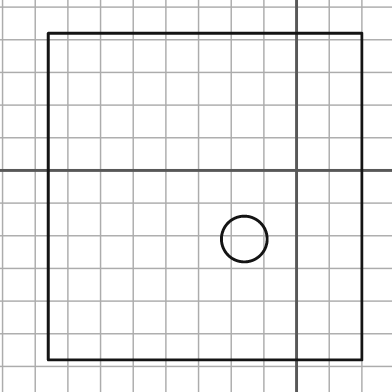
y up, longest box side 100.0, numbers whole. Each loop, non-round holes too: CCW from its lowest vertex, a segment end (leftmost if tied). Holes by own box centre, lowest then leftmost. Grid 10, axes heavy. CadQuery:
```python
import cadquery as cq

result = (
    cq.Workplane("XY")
    .moveTo(-76.0, -58.0)
    .lineTo(20.0, -58.0)
    .lineTo(20.0, 42.0)
    .lineTo(-76.0, 42.0)
    .close()
    .moveTo(-16.0, -21.0)
    .circle(7.0)
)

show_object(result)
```